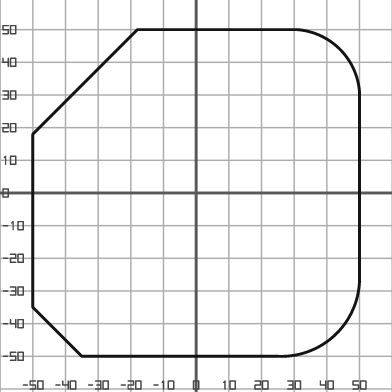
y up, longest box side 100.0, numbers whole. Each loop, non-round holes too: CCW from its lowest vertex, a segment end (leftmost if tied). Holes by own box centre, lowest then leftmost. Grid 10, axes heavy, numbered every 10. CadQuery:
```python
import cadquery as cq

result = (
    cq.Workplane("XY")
    .moveTo(-35.0, -50.0)
    .lineTo(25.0, -50.0)
    .threePointArc((43.0, -43.0), (50.0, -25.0))
    .lineTo(50.0, 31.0)
    .threePointArc((44.0, 44.0), (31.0, 50.0))
    .lineTo(-18.0, 50.0)
    .lineTo(-50.0, 18.0)
    .lineTo(-50.0, -35.0)
    .close()
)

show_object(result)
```